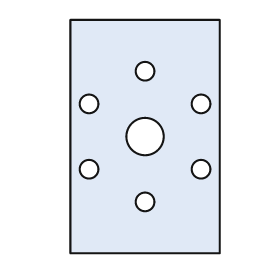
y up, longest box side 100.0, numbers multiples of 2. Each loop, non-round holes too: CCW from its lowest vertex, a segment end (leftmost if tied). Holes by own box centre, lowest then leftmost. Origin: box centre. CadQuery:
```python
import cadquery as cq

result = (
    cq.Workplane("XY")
    .moveTo(-32.0, -50.0)
    .lineTo(32.0, -50.0)
    .lineTo(32.0, 50.0)
    .lineTo(-32.0, 50.0)
    .close()
    .moveTo(0.0, -28.0)
    .circle(4.0)
    .moveTo(-24.0, -14.0)
    .circle(4.0)
    .moveTo(24.0, -14.0)
    .circle(4.0)
    .moveTo(0.0, 0.0)
    .circle(8.0)
    .moveTo(-24.0, 14.0)
    .circle(4.0)
    .moveTo(24.0, 14.0)
    .circle(4.0)
    .moveTo(0.0, 28.0)
    .circle(4.0)
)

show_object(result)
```